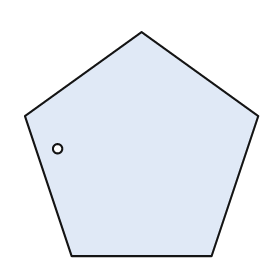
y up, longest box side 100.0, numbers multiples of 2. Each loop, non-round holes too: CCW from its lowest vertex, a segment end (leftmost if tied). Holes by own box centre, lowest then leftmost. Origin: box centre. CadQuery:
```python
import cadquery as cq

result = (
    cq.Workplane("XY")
    .moveTo(-30.0, -48.0)
    .lineTo(30.0, -48.0)
    .lineTo(50.0, 12.0)
    .lineTo(0.0, 48.0)
    .lineTo(-50.0, 12.0)
    .close()
    .moveTo(-36.0, -2.0)
    .circle(2.0)
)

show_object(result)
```